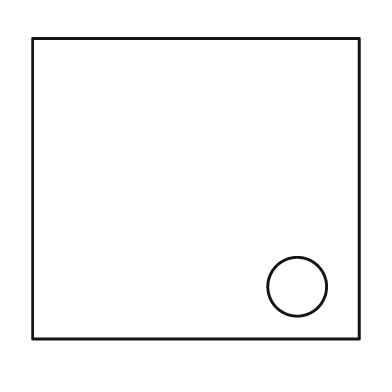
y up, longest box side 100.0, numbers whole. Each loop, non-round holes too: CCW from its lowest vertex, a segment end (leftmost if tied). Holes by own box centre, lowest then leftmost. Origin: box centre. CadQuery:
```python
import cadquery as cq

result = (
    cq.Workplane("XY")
    .moveTo(-50.0, -46.0)
    .lineTo(50.0, -46.0)
    .lineTo(50.0, 46.0)
    .lineTo(-50.0, 46.0)
    .close()
    .moveTo(31.0, -30.0)
    .circle(9.0)
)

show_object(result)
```